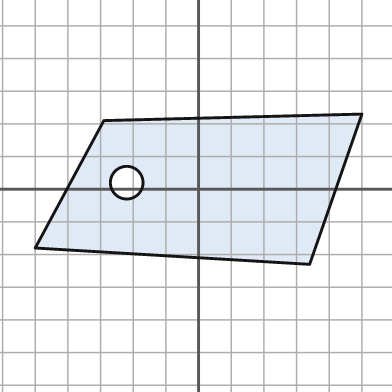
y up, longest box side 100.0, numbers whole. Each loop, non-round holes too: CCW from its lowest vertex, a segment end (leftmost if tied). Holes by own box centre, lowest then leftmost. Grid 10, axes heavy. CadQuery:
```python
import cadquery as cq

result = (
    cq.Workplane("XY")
    .moveTo(34.0, -23.0)
    .lineTo(50.0, 23.0)
    .lineTo(-29.0, 21.0)
    .lineTo(-50.0, -18.0)
    .close()
    .moveTo(-22.0, 2.0)
    .circle(5.0)
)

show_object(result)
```